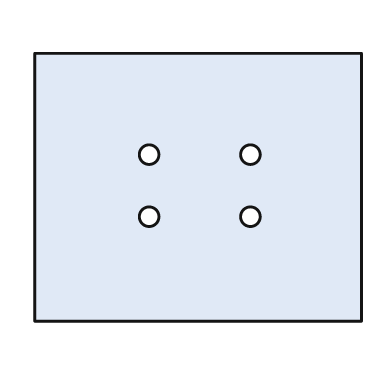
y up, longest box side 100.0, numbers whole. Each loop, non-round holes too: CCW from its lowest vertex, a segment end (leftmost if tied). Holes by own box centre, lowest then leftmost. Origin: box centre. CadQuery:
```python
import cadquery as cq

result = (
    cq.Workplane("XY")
    .moveTo(-50.0, -41.0)
    .lineTo(50.0, -41.0)
    .lineTo(50.0, 41.0)
    .lineTo(-50.0, 41.0)
    .close()
    .moveTo(-15.0, -9.0)
    .circle(3.0)
    .moveTo(16.0, -9.0)
    .circle(3.0)
    .moveTo(-15.0, 10.0)
    .circle(3.0)
    .moveTo(16.0, 10.0)
    .circle(3.0)
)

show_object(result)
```